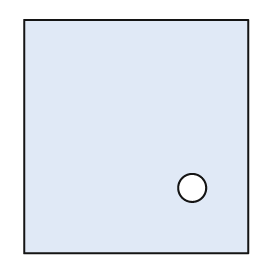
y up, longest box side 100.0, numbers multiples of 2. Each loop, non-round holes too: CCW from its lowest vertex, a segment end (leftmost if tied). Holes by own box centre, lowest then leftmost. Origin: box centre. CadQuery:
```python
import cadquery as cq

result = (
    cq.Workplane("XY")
    .moveTo(-48.0, -50.0)
    .lineTo(48.0, -50.0)
    .lineTo(48.0, 50.0)
    .lineTo(-48.0, 50.0)
    .close()
    .moveTo(24.0, -22.0)
    .circle(6.0)
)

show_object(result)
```